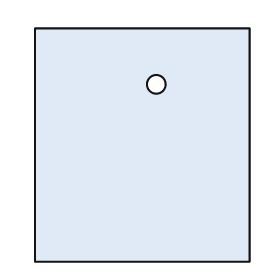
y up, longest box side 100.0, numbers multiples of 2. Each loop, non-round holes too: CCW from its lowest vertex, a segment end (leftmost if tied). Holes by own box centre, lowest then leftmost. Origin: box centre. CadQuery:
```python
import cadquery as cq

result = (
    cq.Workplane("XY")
    .moveTo(-46.0, -50.0)
    .lineTo(46.0, -50.0)
    .lineTo(46.0, 50.0)
    .lineTo(-46.0, 50.0)
    .close()
    .moveTo(6.0, 26.0)
    .circle(4.0)
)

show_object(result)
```